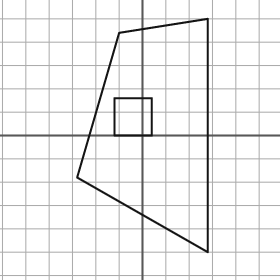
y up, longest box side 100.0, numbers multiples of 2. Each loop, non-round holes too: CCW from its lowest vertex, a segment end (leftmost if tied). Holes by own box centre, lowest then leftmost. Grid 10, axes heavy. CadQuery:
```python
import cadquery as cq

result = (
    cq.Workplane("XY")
    .moveTo(28.0, -50.0)
    .lineTo(28.0, 50.0)
    .lineTo(-10.0, 44.0)
    .lineTo(-28.0, -18.0)
    .close()
    .moveTo(-12.0, 0.0)
    .lineTo(4.0, 0.0)
    .lineTo(4.0, 16.0)
    .lineTo(-12.0, 16.0)
    .close()
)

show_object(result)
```